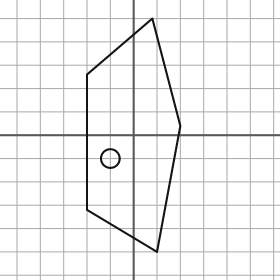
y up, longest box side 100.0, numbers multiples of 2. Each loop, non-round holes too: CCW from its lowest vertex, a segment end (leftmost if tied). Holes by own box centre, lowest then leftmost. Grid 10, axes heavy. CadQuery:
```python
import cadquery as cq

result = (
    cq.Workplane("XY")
    .moveTo(10.0, -50.0)
    .lineTo(20.0, 4.0)
    .lineTo(8.0, 50.0)
    .lineTo(-20.0, 26.0)
    .lineTo(-20.0, -32.0)
    .close()
    .moveTo(-10.0, -10.0)
    .circle(4.0)
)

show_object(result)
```